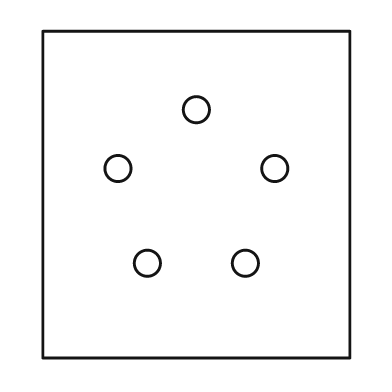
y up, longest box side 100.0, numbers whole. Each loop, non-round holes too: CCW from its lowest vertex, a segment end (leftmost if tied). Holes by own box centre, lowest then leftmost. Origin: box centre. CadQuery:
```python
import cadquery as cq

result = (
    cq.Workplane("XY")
    .moveTo(-47.0, -50.0)
    .lineTo(47.0, -50.0)
    .lineTo(47.0, 50.0)
    .lineTo(-47.0, 50.0)
    .close()
    .moveTo(-15.0, -21.0)
    .circle(4.0)
    .moveTo(15.0, -21.0)
    .circle(4.0)
    .moveTo(-24.0, 8.0)
    .circle(4.0)
    .moveTo(24.0, 8.0)
    .circle(4.0)
    .moveTo(0.0, 26.0)
    .circle(4.0)
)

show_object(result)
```